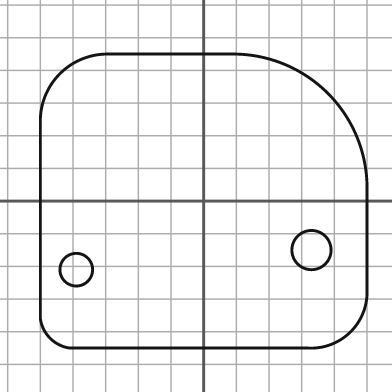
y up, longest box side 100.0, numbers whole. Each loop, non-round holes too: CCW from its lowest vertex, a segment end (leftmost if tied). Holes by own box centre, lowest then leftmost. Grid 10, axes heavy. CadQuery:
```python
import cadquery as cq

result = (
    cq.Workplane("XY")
    .moveTo(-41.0, -45.0)
    .lineTo(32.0, -45.0)
    .threePointArc((45.0, -40.0), (50.0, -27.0))
    .lineTo(50.0, 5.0)
    .threePointArc((38.0, 33.0), (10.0, 45.0))
    .lineTo(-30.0, 45.0)
    .threePointArc((-44.0, 39.0), (-50.0, 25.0))
    .lineTo(-50.0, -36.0)
    .threePointArc((-47.0, -42.0), (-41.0, -45.0))
    .close()
    .moveTo(-39.0, -21.0)
    .circle(5.0)
    .moveTo(33.0, -15.0)
    .circle(6.0)
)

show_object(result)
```